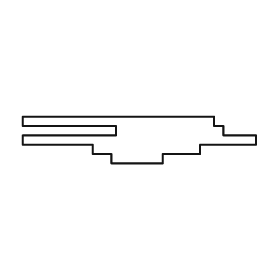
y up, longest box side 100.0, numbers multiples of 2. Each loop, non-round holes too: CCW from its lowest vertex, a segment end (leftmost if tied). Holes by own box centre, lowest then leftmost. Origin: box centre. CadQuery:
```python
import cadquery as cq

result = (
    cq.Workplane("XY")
    .moveTo(-12.0, -10.0)
    .lineTo(10.0, -10.0)
    .lineTo(10.0, -6.0)
    .lineTo(26.0, -6.0)
    .lineTo(26.0, -2.0)
    .lineTo(50.0, -2.0)
    .lineTo(50.0, 2.0)
    .lineTo(36.0, 2.0)
    .lineTo(36.0, 6.0)
    .lineTo(32.0, 6.0)
    .lineTo(32.0, 10.0)
    .lineTo(-50.0, 10.0)
    .lineTo(-50.0, 6.0)
    .lineTo(-10.0, 6.0)
    .lineTo(-10.0, 2.0)
    .lineTo(-50.0, 2.0)
    .lineTo(-50.0, -2.0)
    .lineTo(-20.0, -2.0)
    .lineTo(-20.0, -6.0)
    .lineTo(-12.0, -6.0)
    .close()
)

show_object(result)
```